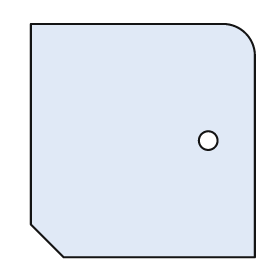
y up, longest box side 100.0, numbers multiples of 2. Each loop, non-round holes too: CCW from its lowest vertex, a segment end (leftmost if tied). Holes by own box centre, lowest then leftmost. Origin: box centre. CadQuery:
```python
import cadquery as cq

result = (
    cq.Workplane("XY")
    .moveTo(-34.0, -50.0)
    .lineTo(48.0, -50.0)
    .lineTo(48.0, 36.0)
    .threePointArc((44.0, 46.0), (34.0, 50.0))
    .lineTo(-48.0, 50.0)
    .lineTo(-48.0, -36.0)
    .close()
    .moveTo(28.0, 0.0)
    .circle(4.0)
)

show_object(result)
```